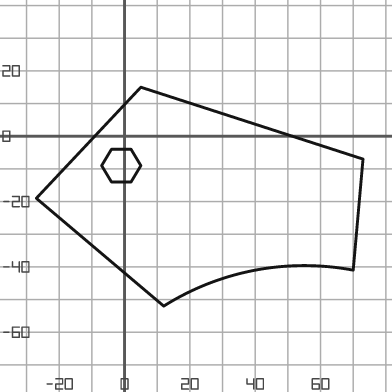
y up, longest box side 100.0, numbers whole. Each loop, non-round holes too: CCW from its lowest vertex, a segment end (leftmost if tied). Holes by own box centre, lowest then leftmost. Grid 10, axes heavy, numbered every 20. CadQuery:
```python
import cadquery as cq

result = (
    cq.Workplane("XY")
    .moveTo(12.0, -52.0)
    .threePointArc((40.0, -41.0), (70.0, -41.0))
    .lineTo(73.0, -7.0)
    .lineTo(5.0, 15.0)
    .lineTo(-27.0, -19.0)
    .close()
    .moveTo(-4.0, -14.0)
    .lineTo(2.0, -14.0)
    .lineTo(5.0, -9.0)
    .lineTo(2.0, -4.0)
    .lineTo(-4.0, -4.0)
    .lineTo(-7.0, -9.0)
    .close()
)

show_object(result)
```